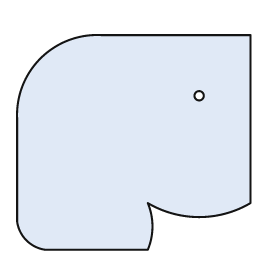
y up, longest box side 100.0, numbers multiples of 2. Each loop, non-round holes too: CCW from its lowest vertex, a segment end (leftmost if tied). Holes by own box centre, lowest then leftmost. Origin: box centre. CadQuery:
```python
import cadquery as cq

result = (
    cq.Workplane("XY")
    .moveTo(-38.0, -46.0)
    .lineTo(6.0, -46.0)
    .threePointArc((8.0, -36.0), (6.0, -26.0))
    .threePointArc((28.0, -32.0), (50.0, -26.0))
    .lineTo(50.0, 46.0)
    .lineTo(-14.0, 46.0)
    .threePointArc((-40.0, 36.0), (-50.0, 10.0))
    .lineTo(-50.0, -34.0)
    .threePointArc((-46.0, -42.0), (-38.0, -46.0))
    .close()
    .moveTo(28.0, 20.0)
    .circle(2.0)
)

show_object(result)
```